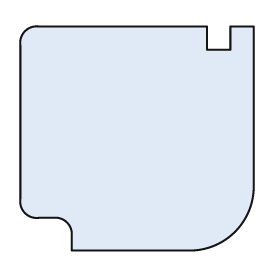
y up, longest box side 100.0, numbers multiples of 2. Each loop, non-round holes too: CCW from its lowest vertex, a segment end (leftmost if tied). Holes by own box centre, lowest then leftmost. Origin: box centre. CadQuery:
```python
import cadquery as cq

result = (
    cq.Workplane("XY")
    .moveTo(-28.0, -48.0)
    .lineTo(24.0, -48.0)
    .threePointArc((42.0, -40.0), (50.0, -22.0))
    .lineTo(50.0, 48.0)
    .lineTo(40.0, 48.0)
    .lineTo(40.0, 38.0)
    .lineTo(30.0, 38.0)
    .lineTo(30.0, 48.0)
    .lineTo(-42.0, 48.0)
    .threePointArc((-48.0, 46.0), (-50.0, 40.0))
    .lineTo(-50.0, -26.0)
    .threePointArc((-48.0, -32.0), (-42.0, -34.0))
    .lineTo(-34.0, -34.0)
    .threePointArc((-30.0, -36.0), (-28.0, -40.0))
    .close()
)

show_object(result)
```